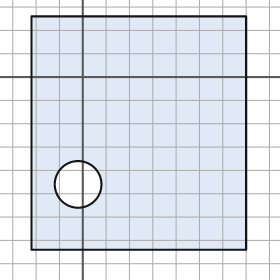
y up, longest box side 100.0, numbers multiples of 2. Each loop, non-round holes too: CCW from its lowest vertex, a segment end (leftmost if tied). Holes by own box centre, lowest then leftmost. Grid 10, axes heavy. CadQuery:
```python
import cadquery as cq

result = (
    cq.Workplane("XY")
    .moveTo(-22.0, -74.0)
    .lineTo(70.0, -74.0)
    .lineTo(70.0, 26.0)
    .lineTo(-22.0, 26.0)
    .close()
    .moveTo(-2.0, -46.0)
    .circle(10.0)
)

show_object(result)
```